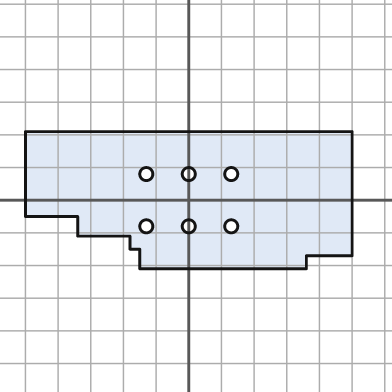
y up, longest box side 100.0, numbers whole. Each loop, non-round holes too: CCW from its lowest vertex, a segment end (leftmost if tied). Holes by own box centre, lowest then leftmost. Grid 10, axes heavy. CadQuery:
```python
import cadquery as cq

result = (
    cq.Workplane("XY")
    .moveTo(-15.0, -21.0)
    .lineTo(36.0, -21.0)
    .lineTo(36.0, -17.0)
    .lineTo(50.0, -17.0)
    .lineTo(50.0, 21.0)
    .lineTo(-50.0, 21.0)
    .lineTo(-50.0, -5.0)
    .lineTo(-34.0, -5.0)
    .lineTo(-34.0, -11.0)
    .lineTo(-18.0, -11.0)
    .lineTo(-18.0, -15.0)
    .lineTo(-15.0, -15.0)
    .close()
    .moveTo(-13.0, -8.0)
    .circle(2.0)
    .moveTo(0.0, -8.0)
    .circle(2.0)
    .moveTo(13.0, -8.0)
    .circle(2.0)
    .moveTo(-13.0, 8.0)
    .circle(2.0)
    .moveTo(0.0, 8.0)
    .circle(2.0)
    .moveTo(13.0, 8.0)
    .circle(2.0)
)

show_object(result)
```